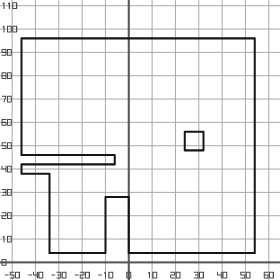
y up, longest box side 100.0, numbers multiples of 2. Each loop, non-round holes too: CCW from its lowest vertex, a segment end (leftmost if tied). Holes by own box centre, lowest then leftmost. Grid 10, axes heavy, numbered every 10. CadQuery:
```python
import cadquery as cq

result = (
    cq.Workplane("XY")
    .moveTo(-34.0, 4.0)
    .lineTo(-10.0, 4.0)
    .lineTo(-10.0, 28.0)
    .lineTo(0.0, 28.0)
    .lineTo(0.0, 4.0)
    .lineTo(54.0, 4.0)
    .lineTo(54.0, 96.0)
    .lineTo(-46.0, 96.0)
    .lineTo(-46.0, 46.0)
    .lineTo(-6.0, 46.0)
    .lineTo(-6.0, 42.0)
    .lineTo(-46.0, 42.0)
    .lineTo(-46.0, 38.0)
    .lineTo(-34.0, 38.0)
    .close()
    .moveTo(24.0, 48.0)
    .lineTo(32.0, 48.0)
    .lineTo(32.0, 56.0)
    .lineTo(24.0, 56.0)
    .close()
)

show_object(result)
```